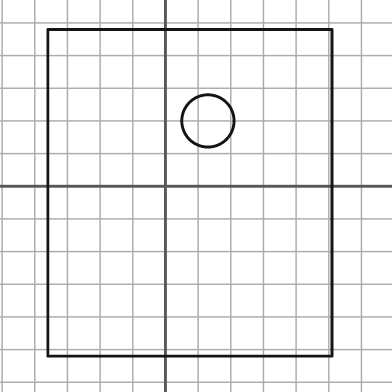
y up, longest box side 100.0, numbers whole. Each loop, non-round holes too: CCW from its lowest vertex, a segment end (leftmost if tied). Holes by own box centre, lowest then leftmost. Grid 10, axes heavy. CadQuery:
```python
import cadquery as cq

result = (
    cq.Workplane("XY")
    .moveTo(-36.0, -52.0)
    .lineTo(51.0, -52.0)
    .lineTo(51.0, 48.0)
    .lineTo(-36.0, 48.0)
    .close()
    .moveTo(13.0, 20.0)
    .circle(8.0)
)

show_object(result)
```